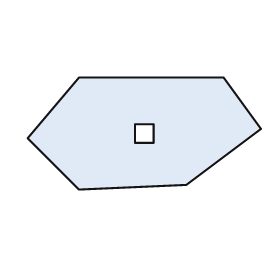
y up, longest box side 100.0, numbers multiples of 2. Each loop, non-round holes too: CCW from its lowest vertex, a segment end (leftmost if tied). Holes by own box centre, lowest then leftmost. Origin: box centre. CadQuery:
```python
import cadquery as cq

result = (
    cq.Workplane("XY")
    .moveTo(-28.0, -24.0)
    .lineTo(18.0, -22.0)
    .lineTo(50.0, 2.0)
    .lineTo(34.0, 24.0)
    .lineTo(-28.0, 24.0)
    .lineTo(-50.0, -2.0)
    .close()
    .moveTo(-4.0, -4.0)
    .lineTo(4.0, -4.0)
    .lineTo(4.0, 4.0)
    .lineTo(-4.0, 4.0)
    .close()
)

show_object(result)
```